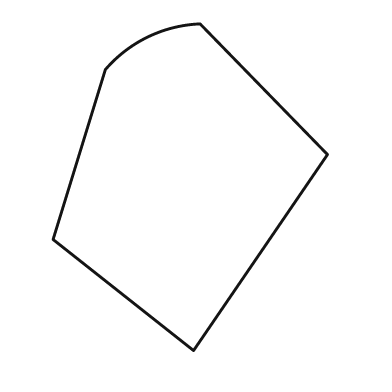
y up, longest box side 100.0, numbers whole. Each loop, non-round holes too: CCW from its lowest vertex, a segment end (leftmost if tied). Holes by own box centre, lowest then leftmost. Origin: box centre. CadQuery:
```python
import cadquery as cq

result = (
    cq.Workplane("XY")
    .moveTo(1.0, -50.0)
    .lineTo(42.0, 10.0)
    .lineTo(3.0, 50.0)
    .threePointArc((-13.0, 46.0), (-26.0, 36.0))
    .lineTo(-42.0, -16.0)
    .close()
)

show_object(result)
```